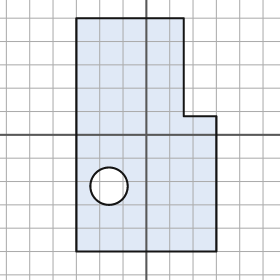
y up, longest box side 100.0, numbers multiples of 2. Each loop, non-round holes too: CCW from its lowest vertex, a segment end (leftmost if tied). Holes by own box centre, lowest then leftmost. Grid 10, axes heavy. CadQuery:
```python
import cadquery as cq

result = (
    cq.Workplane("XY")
    .moveTo(-30.0, -50.0)
    .lineTo(30.0, -50.0)
    .lineTo(30.0, 8.0)
    .lineTo(16.0, 8.0)
    .lineTo(16.0, 50.0)
    .lineTo(-30.0, 50.0)
    .close()
    .moveTo(-16.0, -22.0)
    .circle(8.0)
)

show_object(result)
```